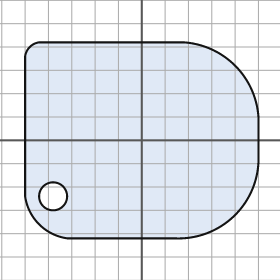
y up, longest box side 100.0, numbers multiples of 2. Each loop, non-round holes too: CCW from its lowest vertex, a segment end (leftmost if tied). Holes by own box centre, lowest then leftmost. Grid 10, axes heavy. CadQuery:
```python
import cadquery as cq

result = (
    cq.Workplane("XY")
    .moveTo(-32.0, -42.0)
    .lineTo(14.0, -42.0)
    .threePointArc((40.0, -32.0), (50.0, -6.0))
    .lineTo(50.0, 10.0)
    .threePointArc((40.0, 32.0), (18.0, 42.0))
    .lineTo(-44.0, 42.0)
    .threePointArc((-48.0, 40.0), (-50.0, 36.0))
    .lineTo(-50.0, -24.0)
    .threePointArc((-44.0, -36.0), (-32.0, -42.0))
    .close()
    .moveTo(-38.0, -24.0)
    .circle(6.0)
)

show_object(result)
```